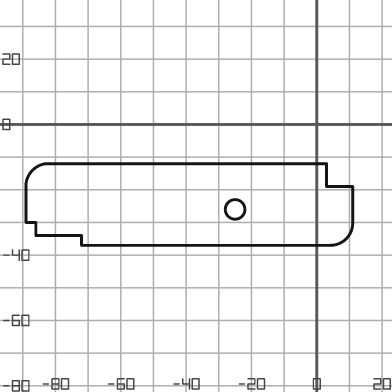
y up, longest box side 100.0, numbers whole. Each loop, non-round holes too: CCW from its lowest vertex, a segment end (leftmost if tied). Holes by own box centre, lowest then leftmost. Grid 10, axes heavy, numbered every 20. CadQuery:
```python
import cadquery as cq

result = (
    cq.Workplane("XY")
    .moveTo(-72.0, -37.0)
    .lineTo(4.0, -37.0)
    .threePointArc((9.0, -35.0), (11.0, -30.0))
    .lineTo(11.0, -19.0)
    .lineTo(3.0, -19.0)
    .lineTo(3.0, -12.0)
    .lineTo(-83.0, -12.0)
    .threePointArc((-87.0, -14.0), (-89.0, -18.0))
    .lineTo(-89.0, -30.0)
    .lineTo(-86.0, -30.0)
    .lineTo(-86.0, -34.0)
    .lineTo(-72.0, -34.0)
    .close()
    .moveTo(-25.0, -26.0)
    .circle(3.0)
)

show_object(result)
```